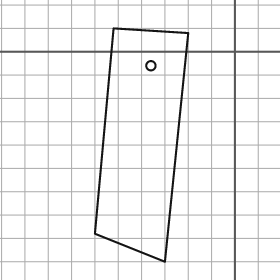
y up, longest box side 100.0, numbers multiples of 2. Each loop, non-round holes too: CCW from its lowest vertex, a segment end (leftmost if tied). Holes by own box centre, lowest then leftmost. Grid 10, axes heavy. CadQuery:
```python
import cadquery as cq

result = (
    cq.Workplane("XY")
    .moveTo(-30.0, -90.0)
    .lineTo(-20.0, 8.0)
    .lineTo(-52.0, 10.0)
    .lineTo(-60.0, -78.0)
    .close()
    .moveTo(-36.0, -6.0)
    .circle(2.0)
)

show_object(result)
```